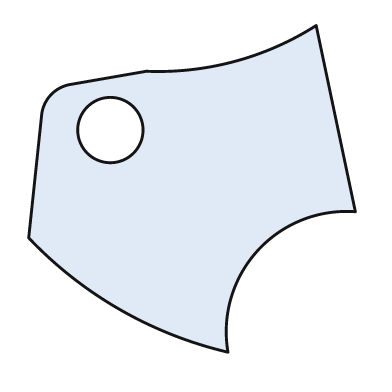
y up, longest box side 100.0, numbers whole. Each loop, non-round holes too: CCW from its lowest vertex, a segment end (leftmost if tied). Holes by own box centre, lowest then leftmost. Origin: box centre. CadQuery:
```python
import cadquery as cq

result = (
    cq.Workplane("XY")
    .moveTo(11.0, -50.0)
    .threePointArc((20.0, -19.0), (50.0, -7.0))
    .lineTo(38.0, 50.0)
    .threePointArc((13.0, 39.0), (-14.0, 36.0))
    .lineTo(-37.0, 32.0)
    .threePointArc((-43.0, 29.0), (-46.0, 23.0))
    .lineTo(-50.0, -15.0)
    .threePointArc((-22.0, -37.0), (11.0, -50.0))
    .close()
    .moveTo(-25.0, 18.0)
    .circle(10.0)
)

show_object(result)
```